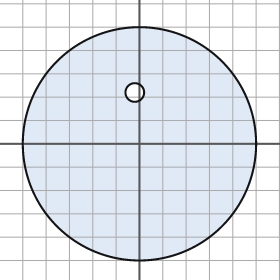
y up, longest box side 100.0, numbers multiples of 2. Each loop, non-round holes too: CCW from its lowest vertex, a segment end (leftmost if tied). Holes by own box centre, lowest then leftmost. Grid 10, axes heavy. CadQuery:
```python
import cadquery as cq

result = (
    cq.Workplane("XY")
    .moveTo(0.0, 0.0)
    .circle(50.0)
    .moveTo(-2.0, 22.0)
    .circle(4.0)
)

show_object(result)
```